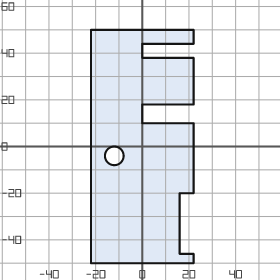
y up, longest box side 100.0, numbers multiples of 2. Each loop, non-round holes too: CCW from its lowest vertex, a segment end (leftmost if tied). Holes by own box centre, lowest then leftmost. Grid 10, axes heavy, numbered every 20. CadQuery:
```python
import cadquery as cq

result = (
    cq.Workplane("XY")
    .moveTo(-22.0, -50.0)
    .lineTo(22.0, -50.0)
    .lineTo(22.0, -46.0)
    .lineTo(16.0, -46.0)
    .lineTo(16.0, -20.0)
    .lineTo(22.0, -20.0)
    .lineTo(22.0, 10.0)
    .lineTo(0.0, 10.0)
    .lineTo(0.0, 18.0)
    .lineTo(22.0, 18.0)
    .lineTo(22.0, 38.0)
    .lineTo(0.0, 38.0)
    .lineTo(0.0, 44.0)
    .lineTo(22.0, 44.0)
    .lineTo(22.0, 50.0)
    .lineTo(-22.0, 50.0)
    .close()
    .moveTo(-12.0, -4.0)
    .circle(4.0)
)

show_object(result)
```